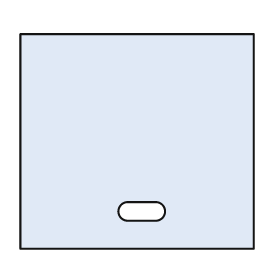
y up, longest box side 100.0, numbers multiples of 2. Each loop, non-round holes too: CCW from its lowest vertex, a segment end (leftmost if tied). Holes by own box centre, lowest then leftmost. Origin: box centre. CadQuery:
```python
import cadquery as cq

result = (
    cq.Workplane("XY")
    .moveTo(-50.0, -46.0)
    .lineTo(50.0, -46.0)
    .lineTo(50.0, 46.0)
    .lineTo(-50.0, 46.0)
    .close()
    .moveTo(-4.0, -34.0)
    .lineTo(8.0, -34.0)
    .threePointArc((12.0, -30.0), (8.0, -26.0))
    .lineTo(-4.0, -26.0)
    .threePointArc((-8.0, -30.0), (-4.0, -34.0))
    .close()
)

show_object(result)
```